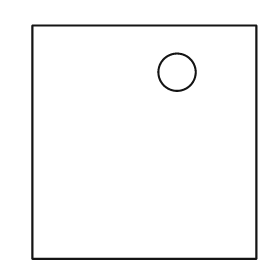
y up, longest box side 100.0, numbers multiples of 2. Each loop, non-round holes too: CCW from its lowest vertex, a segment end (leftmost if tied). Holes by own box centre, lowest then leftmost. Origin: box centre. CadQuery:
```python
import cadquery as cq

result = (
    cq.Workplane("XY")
    .moveTo(-48.0, -50.0)
    .lineTo(48.0, -50.0)
    .lineTo(48.0, 50.0)
    .lineTo(-48.0, 50.0)
    .close()
    .moveTo(14.0, 30.0)
    .circle(8.0)
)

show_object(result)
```